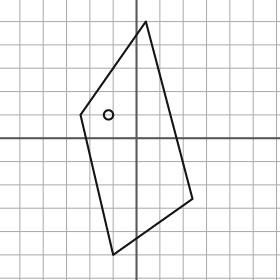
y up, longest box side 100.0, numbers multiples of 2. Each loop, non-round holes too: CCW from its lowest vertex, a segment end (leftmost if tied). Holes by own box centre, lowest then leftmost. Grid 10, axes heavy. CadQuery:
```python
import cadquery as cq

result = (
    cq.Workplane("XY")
    .moveTo(-10.0, -50.0)
    .lineTo(24.0, -26.0)
    .lineTo(4.0, 50.0)
    .lineTo(-24.0, 10.0)
    .close()
    .moveTo(-12.0, 10.0)
    .circle(2.0)
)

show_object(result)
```